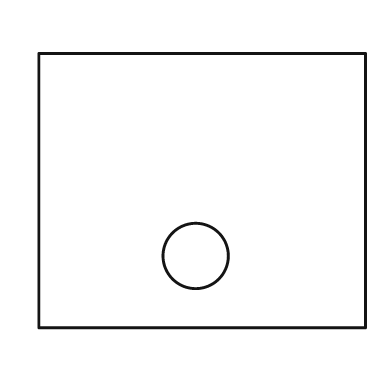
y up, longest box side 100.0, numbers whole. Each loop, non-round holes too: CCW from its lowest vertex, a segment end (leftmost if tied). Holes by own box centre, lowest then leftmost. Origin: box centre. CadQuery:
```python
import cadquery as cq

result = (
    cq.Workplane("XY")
    .moveTo(-50.0, -42.0)
    .lineTo(50.0, -42.0)
    .lineTo(50.0, 42.0)
    .lineTo(-50.0, 42.0)
    .close()
    .moveTo(-2.0, -20.0)
    .circle(10.0)
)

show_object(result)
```